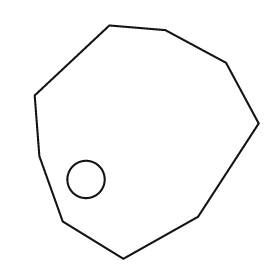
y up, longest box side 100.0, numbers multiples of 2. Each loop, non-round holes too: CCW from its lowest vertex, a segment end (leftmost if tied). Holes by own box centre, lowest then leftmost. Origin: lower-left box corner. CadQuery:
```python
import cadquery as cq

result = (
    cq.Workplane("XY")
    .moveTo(38.0, 0.0)
    .lineTo(70.0, 18.0)
    .lineTo(96.0, 58.0)
    .lineTo(82.0, 84.0)
    .lineTo(56.0, 98.0)
    .lineTo(32.0, 100.0)
    .lineTo(0.0, 70.0)
    .lineTo(2.0, 44.0)
    .lineTo(12.0, 16.0)
    .close()
    .moveTo(22.0, 34.0)
    .circle(8.0)
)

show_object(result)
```